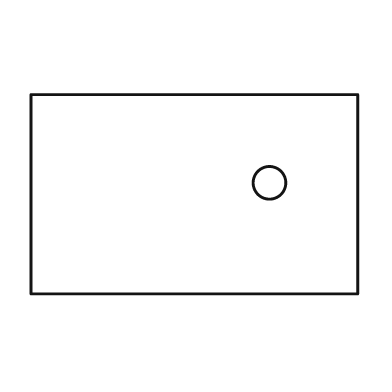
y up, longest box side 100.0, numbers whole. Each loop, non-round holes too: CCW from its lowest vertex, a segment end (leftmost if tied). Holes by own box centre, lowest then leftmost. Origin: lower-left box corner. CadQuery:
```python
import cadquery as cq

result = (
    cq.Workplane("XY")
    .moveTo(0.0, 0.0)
    .lineTo(100.0, 0.0)
    .lineTo(100.0, 61.0)
    .lineTo(0.0, 61.0)
    .close()
    .moveTo(73.0, 34.0)
    .circle(5.0)
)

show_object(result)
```